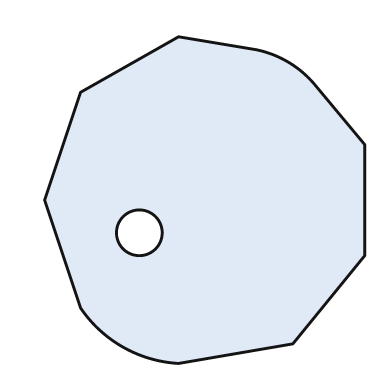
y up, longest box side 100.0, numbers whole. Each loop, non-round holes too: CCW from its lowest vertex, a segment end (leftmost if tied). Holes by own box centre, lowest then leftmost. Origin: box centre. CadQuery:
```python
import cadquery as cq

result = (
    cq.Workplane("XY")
    .moveTo(-8.0, -50.0)
    .lineTo(27.0, -44.0)
    .lineTo(49.0, -17.0)
    .lineTo(49.0, 17.0)
    .lineTo(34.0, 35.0)
    .threePointArc((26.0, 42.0), (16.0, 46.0))
    .lineTo(-8.0, 50.0)
    .lineTo(-38.0, 33.0)
    .lineTo(-49.0, 0.0)
    .lineTo(-38.0, -33.0)
    .threePointArc((-25.0, -45.0), (-8.0, -50.0))
    .close()
    .moveTo(-20.0, -10.0)
    .circle(7.0)
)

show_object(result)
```